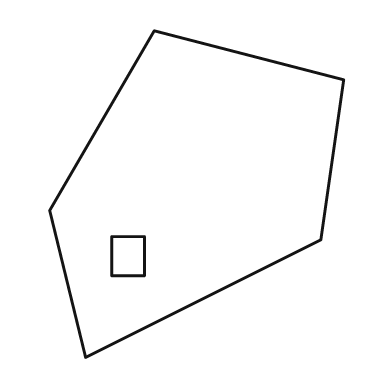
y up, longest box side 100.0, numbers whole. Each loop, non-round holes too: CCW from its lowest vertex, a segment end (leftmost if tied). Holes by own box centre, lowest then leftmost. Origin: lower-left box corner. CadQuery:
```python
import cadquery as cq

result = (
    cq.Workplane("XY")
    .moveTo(11.0, 0.0)
    .lineTo(83.0, 36.0)
    .lineTo(90.0, 85.0)
    .lineTo(32.0, 100.0)
    .lineTo(0.0, 45.0)
    .close()
    .moveTo(19.0, 25.0)
    .lineTo(29.0, 25.0)
    .lineTo(29.0, 37.0)
    .lineTo(19.0, 37.0)
    .close()
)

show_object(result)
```